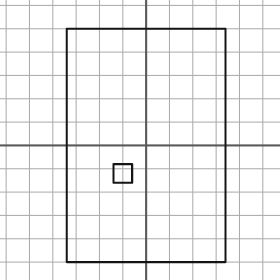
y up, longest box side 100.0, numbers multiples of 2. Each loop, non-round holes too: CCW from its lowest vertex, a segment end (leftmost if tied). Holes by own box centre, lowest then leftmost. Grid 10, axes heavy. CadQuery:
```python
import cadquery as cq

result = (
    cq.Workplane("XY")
    .moveTo(-34.0, -50.0)
    .lineTo(34.0, -50.0)
    .lineTo(34.0, 50.0)
    .lineTo(-34.0, 50.0)
    .close()
    .moveTo(-14.0, -16.0)
    .lineTo(-6.0, -16.0)
    .lineTo(-6.0, -8.0)
    .lineTo(-14.0, -8.0)
    .close()
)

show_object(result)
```